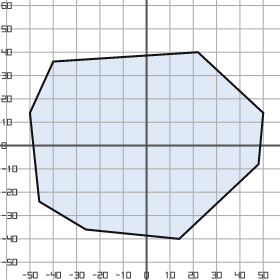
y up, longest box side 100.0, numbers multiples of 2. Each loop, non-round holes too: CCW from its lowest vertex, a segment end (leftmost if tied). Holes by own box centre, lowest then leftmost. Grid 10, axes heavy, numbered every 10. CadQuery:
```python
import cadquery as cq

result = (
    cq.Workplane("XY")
    .moveTo(14.0, -40.0)
    .lineTo(48.0, -8.0)
    .lineTo(50.0, 14.0)
    .lineTo(22.0, 40.0)
    .lineTo(-40.0, 36.0)
    .lineTo(-50.0, 14.0)
    .lineTo(-46.0, -24.0)
    .lineTo(-26.0, -36.0)
    .close()
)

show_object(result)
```